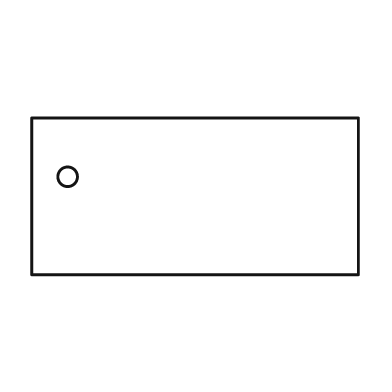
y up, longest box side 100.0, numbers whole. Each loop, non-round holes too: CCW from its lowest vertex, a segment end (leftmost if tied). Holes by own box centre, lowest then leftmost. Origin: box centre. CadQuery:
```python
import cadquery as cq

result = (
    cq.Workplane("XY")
    .moveTo(-50.0, -24.0)
    .lineTo(50.0, -24.0)
    .lineTo(50.0, 24.0)
    .lineTo(-50.0, 24.0)
    .close()
    .moveTo(-39.0, 6.0)
    .circle(3.0)
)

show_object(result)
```